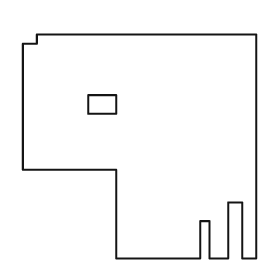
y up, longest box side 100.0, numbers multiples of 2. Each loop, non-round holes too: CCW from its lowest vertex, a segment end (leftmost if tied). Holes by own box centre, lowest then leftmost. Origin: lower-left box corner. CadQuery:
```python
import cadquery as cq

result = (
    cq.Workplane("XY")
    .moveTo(40.0, 0.0)
    .lineTo(76.0, 0.0)
    .lineTo(76.0, 16.0)
    .lineTo(80.0, 16.0)
    .lineTo(80.0, 0.0)
    .lineTo(88.0, 0.0)
    .lineTo(88.0, 24.0)
    .lineTo(94.0, 24.0)
    .lineTo(94.0, 0.0)
    .lineTo(100.0, 0.0)
    .lineTo(100.0, 96.0)
    .lineTo(6.0, 96.0)
    .lineTo(6.0, 92.0)
    .lineTo(0.0, 92.0)
    .lineTo(0.0, 38.0)
    .lineTo(40.0, 38.0)
    .close()
    .moveTo(28.0, 62.0)
    .lineTo(40.0, 62.0)
    .lineTo(40.0, 70.0)
    .lineTo(28.0, 70.0)
    .close()
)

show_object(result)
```